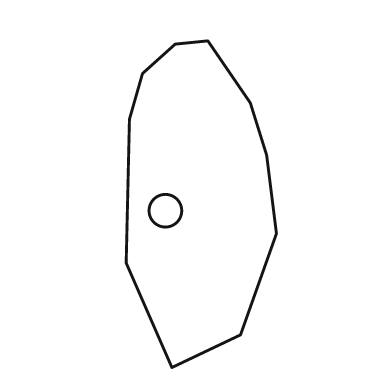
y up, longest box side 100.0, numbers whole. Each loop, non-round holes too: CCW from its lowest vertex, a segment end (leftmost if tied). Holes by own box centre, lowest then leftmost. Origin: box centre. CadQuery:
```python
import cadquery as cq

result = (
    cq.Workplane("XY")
    .moveTo(-9.0, -50.0)
    .lineTo(12.0, -40.0)
    .lineTo(23.0, -9.0)
    .lineTo(20.0, 15.0)
    .lineTo(15.0, 31.0)
    .lineTo(2.0, 50.0)
    .lineTo(-8.0, 49.0)
    .lineTo(-18.0, 40.0)
    .lineTo(-22.0, 26.0)
    .lineTo(-23.0, -18.0)
    .close()
    .moveTo(-11.0, -2.0)
    .circle(5.0)
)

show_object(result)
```